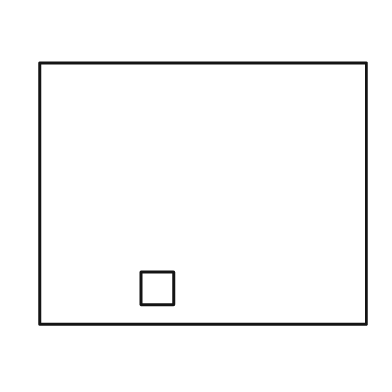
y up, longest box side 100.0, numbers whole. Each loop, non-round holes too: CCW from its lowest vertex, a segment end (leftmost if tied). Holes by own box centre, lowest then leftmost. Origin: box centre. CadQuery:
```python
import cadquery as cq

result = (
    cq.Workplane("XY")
    .moveTo(-50.0, -40.0)
    .lineTo(50.0, -40.0)
    .lineTo(50.0, 40.0)
    .lineTo(-50.0, 40.0)
    .close()
    .moveTo(-19.0, -34.0)
    .lineTo(-9.0, -34.0)
    .lineTo(-9.0, -24.0)
    .lineTo(-19.0, -24.0)
    .close()
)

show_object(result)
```